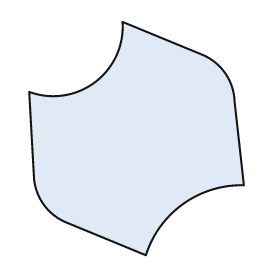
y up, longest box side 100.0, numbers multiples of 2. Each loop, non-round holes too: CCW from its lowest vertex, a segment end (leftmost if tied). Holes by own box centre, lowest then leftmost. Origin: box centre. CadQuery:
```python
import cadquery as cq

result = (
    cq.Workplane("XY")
    .moveTo(4.0, -50.0)
    .threePointArc((20.0, -28.0), (46.0, -20.0))
    .lineTo(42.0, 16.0)
    .threePointArc((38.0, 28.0), (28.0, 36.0))
    .lineTo(-6.0, 50.0)
    .threePointArc((-18.0, 24.0), (-46.0, 20.0))
    .lineTo(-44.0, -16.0)
    .threePointArc((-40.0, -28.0), (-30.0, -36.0))
    .close()
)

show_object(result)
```